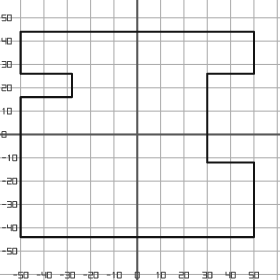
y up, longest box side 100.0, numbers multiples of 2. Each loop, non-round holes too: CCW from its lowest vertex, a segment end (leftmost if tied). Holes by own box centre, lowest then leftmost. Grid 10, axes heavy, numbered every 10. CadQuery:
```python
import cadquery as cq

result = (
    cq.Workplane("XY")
    .moveTo(-50.0, -44.0)
    .lineTo(50.0, -44.0)
    .lineTo(50.0, -12.0)
    .lineTo(30.0, -12.0)
    .lineTo(30.0, 26.0)
    .lineTo(50.0, 26.0)
    .lineTo(50.0, 44.0)
    .lineTo(-50.0, 44.0)
    .lineTo(-50.0, 26.0)
    .lineTo(-28.0, 26.0)
    .lineTo(-28.0, 16.0)
    .lineTo(-50.0, 16.0)
    .close()
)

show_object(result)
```